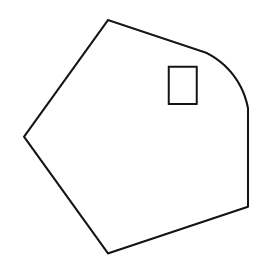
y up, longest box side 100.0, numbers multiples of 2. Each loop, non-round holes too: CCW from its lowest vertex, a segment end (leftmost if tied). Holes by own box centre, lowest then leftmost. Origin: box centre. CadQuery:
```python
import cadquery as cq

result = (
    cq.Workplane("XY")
    .moveTo(-12.0, -50.0)
    .lineTo(48.0, -30.0)
    .lineTo(48.0, 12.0)
    .threePointArc((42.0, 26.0), (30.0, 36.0))
    .lineTo(-12.0, 50.0)
    .lineTo(-48.0, 0.0)
    .close()
    .moveTo(14.0, 14.0)
    .lineTo(26.0, 14.0)
    .lineTo(26.0, 30.0)
    .lineTo(14.0, 30.0)
    .close()
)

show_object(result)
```